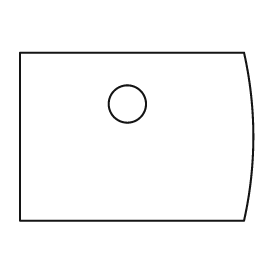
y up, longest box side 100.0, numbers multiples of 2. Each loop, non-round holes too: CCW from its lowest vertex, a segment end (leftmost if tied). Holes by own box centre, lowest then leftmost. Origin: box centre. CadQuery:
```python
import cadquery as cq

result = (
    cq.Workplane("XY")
    .moveTo(-50.0, -36.0)
    .lineTo(46.0, -36.0)
    .threePointArc((50.0, 0.0), (46.0, 36.0))
    .lineTo(-50.0, 36.0)
    .close()
    .moveTo(-4.0, 14.0)
    .circle(8.0)
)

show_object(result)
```